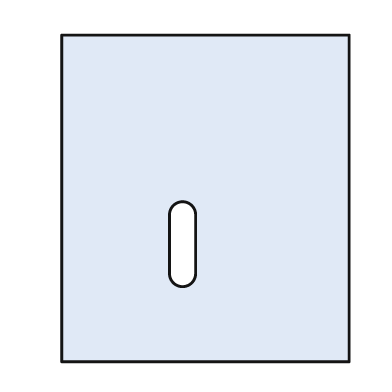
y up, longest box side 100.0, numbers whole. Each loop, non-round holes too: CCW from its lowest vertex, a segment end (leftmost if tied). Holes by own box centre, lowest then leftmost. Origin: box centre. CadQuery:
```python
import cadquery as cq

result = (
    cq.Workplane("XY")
    .moveTo(-44.0, -50.0)
    .lineTo(44.0, -50.0)
    .lineTo(44.0, 50.0)
    .lineTo(-44.0, 50.0)
    .close()
    .moveTo(-11.0, -23.0)
    .threePointArc((-7.0, -27.0), (-3.0, -23.0))
    .lineTo(-3.0, -5.0)
    .threePointArc((-7.0, -1.0), (-11.0, -5.0))
    .close()
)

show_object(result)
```